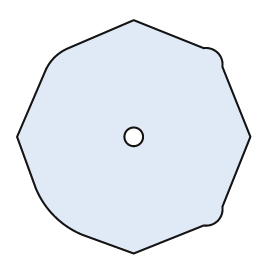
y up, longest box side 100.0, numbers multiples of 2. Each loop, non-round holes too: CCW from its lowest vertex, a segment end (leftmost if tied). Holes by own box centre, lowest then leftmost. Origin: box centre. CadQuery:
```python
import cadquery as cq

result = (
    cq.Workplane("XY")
    .moveTo(0.0, -50.0)
    .lineTo(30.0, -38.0)
    .threePointArc((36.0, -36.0), (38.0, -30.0))
    .lineTo(50.0, 0.0)
    .lineTo(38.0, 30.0)
    .threePointArc((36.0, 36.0), (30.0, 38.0))
    .lineTo(0.0, 50.0)
    .lineTo(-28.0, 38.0)
    .threePointArc((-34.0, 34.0), (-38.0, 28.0))
    .lineTo(-50.0, 0.0)
    .lineTo(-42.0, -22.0)
    .threePointArc((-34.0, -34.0), (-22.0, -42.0))
    .close()
    .moveTo(0.0, 0.0)
    .circle(4.0)
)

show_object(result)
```